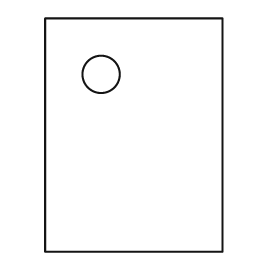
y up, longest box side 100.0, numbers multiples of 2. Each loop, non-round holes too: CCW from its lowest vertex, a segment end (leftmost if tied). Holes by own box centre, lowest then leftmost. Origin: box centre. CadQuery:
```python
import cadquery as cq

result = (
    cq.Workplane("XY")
    .moveTo(-38.0, -50.0)
    .lineTo(38.0, -50.0)
    .lineTo(38.0, 50.0)
    .lineTo(-38.0, 50.0)
    .close()
    .moveTo(-14.0, 26.0)
    .circle(8.0)
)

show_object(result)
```